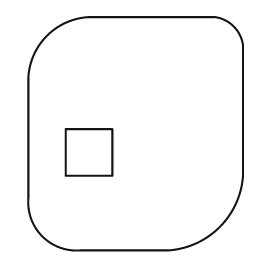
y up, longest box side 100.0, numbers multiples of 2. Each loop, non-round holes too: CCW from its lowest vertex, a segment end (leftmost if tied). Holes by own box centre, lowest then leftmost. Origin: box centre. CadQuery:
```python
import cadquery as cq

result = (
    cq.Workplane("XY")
    .moveTo(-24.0, -50.0)
    .lineTo(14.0, -50.0)
    .threePointArc((36.0, -40.0), (46.0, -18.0))
    .lineTo(46.0, 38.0)
    .threePointArc((42.0, 46.0), (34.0, 50.0))
    .lineTo(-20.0, 50.0)
    .threePointArc((-38.0, 42.0), (-46.0, 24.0))
    .lineTo(-46.0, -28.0)
    .threePointArc((-40.0, -44.0), (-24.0, -50.0))
    .close()
    .moveTo(-30.0, -18.0)
    .lineTo(-10.0, -18.0)
    .lineTo(-10.0, 2.0)
    .lineTo(-30.0, 2.0)
    .close()
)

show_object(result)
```